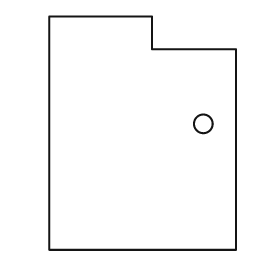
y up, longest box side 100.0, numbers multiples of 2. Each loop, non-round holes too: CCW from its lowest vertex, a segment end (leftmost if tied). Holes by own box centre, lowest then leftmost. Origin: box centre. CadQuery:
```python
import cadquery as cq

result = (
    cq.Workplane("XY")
    .moveTo(-40.0, -50.0)
    .lineTo(40.0, -50.0)
    .lineTo(40.0, 36.0)
    .lineTo(4.0, 36.0)
    .lineTo(4.0, 50.0)
    .lineTo(-40.0, 50.0)
    .close()
    .moveTo(26.0, 4.0)
    .circle(4.0)
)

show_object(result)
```